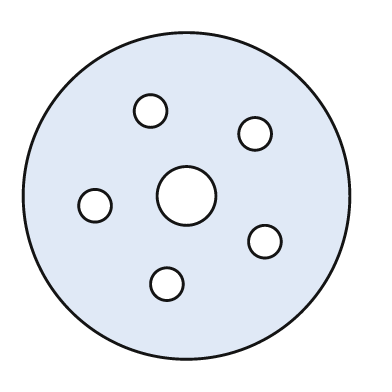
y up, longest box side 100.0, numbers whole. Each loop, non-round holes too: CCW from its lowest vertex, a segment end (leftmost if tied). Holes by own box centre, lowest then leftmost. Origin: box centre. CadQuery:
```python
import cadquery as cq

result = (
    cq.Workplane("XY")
    .moveTo(0.0, 0.0)
    .circle(50.0)
    .moveTo(-6.0, -27.0)
    .circle(5.0)
    .moveTo(24.0, -14.0)
    .circle(5.0)
    .moveTo(-28.0, -3.0)
    .circle(5.0)
    .moveTo(0.0, 0.0)
    .circle(9.0)
    .moveTo(21.0, 19.0)
    .circle(5.0)
    .moveTo(-11.0, 26.0)
    .circle(5.0)
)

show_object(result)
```